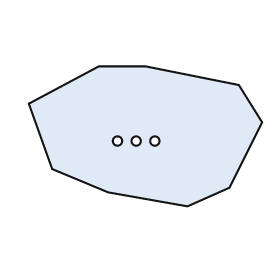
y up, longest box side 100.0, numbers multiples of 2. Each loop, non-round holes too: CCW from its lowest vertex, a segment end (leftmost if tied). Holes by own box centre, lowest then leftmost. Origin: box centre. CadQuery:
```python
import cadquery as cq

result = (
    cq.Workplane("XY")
    .moveTo(18.0, -30.0)
    .lineTo(36.0, -22.0)
    .lineTo(50.0, 6.0)
    .lineTo(40.0, 22.0)
    .lineTo(0.0, 30.0)
    .lineTo(-20.0, 30.0)
    .lineTo(-50.0, 14.0)
    .lineTo(-40.0, -14.0)
    .lineTo(-16.0, -24.0)
    .close()
    .moveTo(-12.0, -2.0)
    .circle(2.0)
    .moveTo(-4.0, -2.0)
    .circle(2.0)
    .moveTo(4.0, -2.0)
    .circle(2.0)
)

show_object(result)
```